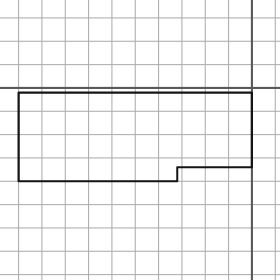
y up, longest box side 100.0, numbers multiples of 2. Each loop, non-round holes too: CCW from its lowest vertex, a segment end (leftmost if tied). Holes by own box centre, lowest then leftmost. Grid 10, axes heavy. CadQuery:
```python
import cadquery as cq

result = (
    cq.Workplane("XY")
    .moveTo(-100.0, -40.0)
    .lineTo(-32.0, -40.0)
    .lineTo(-32.0, -34.0)
    .lineTo(0.0, -34.0)
    .lineTo(0.0, -2.0)
    .lineTo(-100.0, -2.0)
    .close()
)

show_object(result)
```